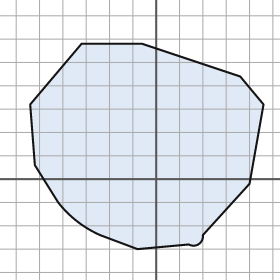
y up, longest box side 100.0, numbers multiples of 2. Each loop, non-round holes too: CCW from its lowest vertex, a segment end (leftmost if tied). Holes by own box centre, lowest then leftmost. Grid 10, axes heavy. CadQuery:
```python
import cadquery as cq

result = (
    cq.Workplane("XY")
    .moveTo(-8.0, -30.0)
    .lineTo(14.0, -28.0)
    .threePointArc((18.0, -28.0), (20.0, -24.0))
    .lineTo(40.0, -2.0)
    .lineTo(46.0, 32.0)
    .lineTo(36.0, 44.0)
    .lineTo(-6.0, 58.0)
    .lineTo(-32.0, 58.0)
    .lineTo(-54.0, 32.0)
    .lineTo(-52.0, 6.0)
    .lineTo(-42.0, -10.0)
    .threePointArc((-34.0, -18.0), (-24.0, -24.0))
    .close()
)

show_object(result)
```